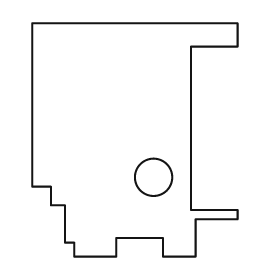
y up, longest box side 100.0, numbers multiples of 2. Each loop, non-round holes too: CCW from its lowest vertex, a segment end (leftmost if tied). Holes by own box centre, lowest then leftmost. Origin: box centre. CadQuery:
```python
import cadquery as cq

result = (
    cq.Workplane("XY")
    .moveTo(-26.0, -50.0)
    .lineTo(-8.0, -50.0)
    .lineTo(-8.0, -42.0)
    .lineTo(12.0, -42.0)
    .lineTo(12.0, -50.0)
    .lineTo(26.0, -50.0)
    .lineTo(26.0, -34.0)
    .lineTo(44.0, -34.0)
    .lineTo(44.0, -30.0)
    .lineTo(24.0, -30.0)
    .lineTo(24.0, 40.0)
    .lineTo(44.0, 40.0)
    .lineTo(44.0, 50.0)
    .lineTo(-44.0, 50.0)
    .lineTo(-44.0, -20.0)
    .lineTo(-36.0, -20.0)
    .lineTo(-36.0, -28.0)
    .lineTo(-30.0, -28.0)
    .lineTo(-30.0, -44.0)
    .lineTo(-26.0, -44.0)
    .close()
    .moveTo(8.0, -16.0)
    .circle(8.0)
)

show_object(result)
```